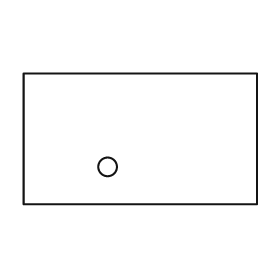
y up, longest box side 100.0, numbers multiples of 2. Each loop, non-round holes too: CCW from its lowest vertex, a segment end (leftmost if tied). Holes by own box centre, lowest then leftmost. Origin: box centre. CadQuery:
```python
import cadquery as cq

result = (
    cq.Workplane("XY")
    .moveTo(-50.0, -28.0)
    .lineTo(50.0, -28.0)
    .lineTo(50.0, 28.0)
    .lineTo(-50.0, 28.0)
    .close()
    .moveTo(-14.0, -12.0)
    .circle(4.0)
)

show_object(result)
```